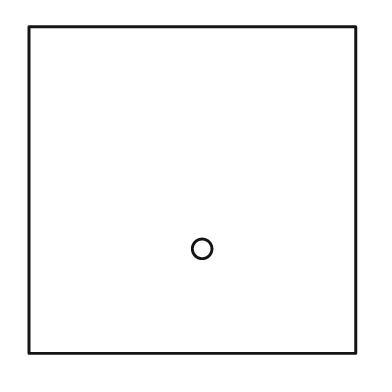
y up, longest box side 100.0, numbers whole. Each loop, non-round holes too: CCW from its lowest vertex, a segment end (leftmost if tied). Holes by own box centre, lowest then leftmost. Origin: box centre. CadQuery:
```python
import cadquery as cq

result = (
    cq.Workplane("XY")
    .moveTo(-50.0, -50.0)
    .lineTo(50.0, -50.0)
    .lineTo(50.0, 50.0)
    .lineTo(-50.0, 50.0)
    .close()
    .moveTo(3.0, -18.0)
    .circle(3.0)
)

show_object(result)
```